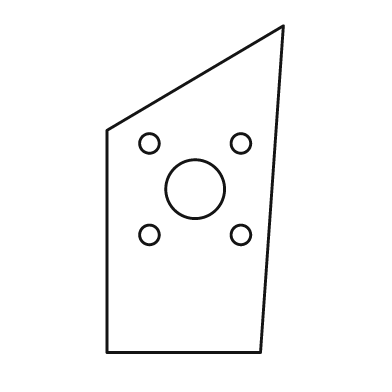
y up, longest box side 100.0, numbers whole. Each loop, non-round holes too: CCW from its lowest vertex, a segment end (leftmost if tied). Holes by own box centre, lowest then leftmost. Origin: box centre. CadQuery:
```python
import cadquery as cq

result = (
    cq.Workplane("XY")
    .moveTo(-27.0, -50.0)
    .lineTo(20.0, -50.0)
    .lineTo(27.0, 50.0)
    .lineTo(-27.0, 18.0)
    .close()
    .moveTo(-14.0, -14.0)
    .circle(3.0)
    .moveTo(14.0, -14.0)
    .circle(3.0)
    .moveTo(0.0, 0.0)
    .circle(9.0)
    .moveTo(-14.0, 14.0)
    .circle(3.0)
    .moveTo(14.0, 14.0)
    .circle(3.0)
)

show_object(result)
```